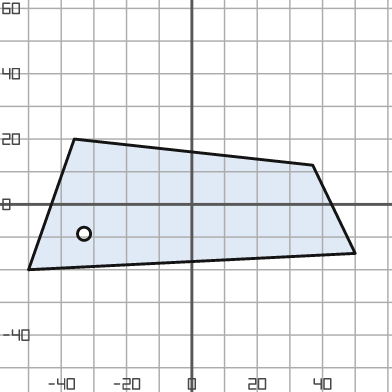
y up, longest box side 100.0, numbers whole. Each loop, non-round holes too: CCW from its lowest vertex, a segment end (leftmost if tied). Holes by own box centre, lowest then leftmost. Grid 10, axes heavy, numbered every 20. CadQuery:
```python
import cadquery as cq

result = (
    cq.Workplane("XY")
    .moveTo(-50.0, -20.0)
    .lineTo(50.0, -15.0)
    .lineTo(37.0, 12.0)
    .lineTo(-36.0, 20.0)
    .close()
    .moveTo(-33.0, -9.0)
    .circle(2.0)
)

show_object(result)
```